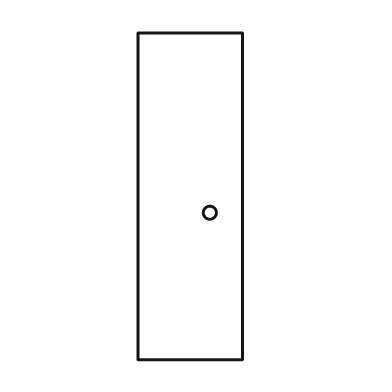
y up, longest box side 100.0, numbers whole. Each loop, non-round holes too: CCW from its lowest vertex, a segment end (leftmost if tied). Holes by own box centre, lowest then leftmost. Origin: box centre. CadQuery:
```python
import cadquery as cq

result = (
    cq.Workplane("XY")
    .moveTo(-16.0, -50.0)
    .lineTo(16.0, -50.0)
    .lineTo(16.0, 50.0)
    .lineTo(-16.0, 50.0)
    .close()
    .moveTo(6.0, -5.0)
    .circle(2.0)
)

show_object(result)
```